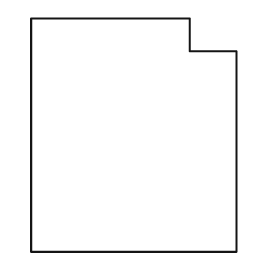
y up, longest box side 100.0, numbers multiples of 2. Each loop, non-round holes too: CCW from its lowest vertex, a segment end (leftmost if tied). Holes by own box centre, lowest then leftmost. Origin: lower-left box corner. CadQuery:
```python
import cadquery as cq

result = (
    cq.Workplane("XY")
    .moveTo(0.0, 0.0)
    .lineTo(88.0, 0.0)
    .lineTo(88.0, 86.0)
    .lineTo(68.0, 86.0)
    .lineTo(68.0, 100.0)
    .lineTo(0.0, 100.0)
    .close()
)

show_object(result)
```